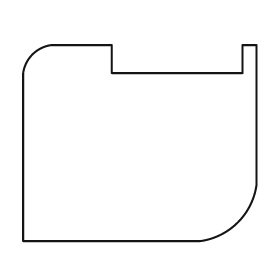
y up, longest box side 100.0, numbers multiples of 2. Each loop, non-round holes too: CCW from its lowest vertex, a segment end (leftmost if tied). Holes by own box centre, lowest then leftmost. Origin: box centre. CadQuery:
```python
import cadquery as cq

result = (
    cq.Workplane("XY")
    .moveTo(-50.0, -42.0)
    .lineTo(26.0, -42.0)
    .threePointArc((42.0, -34.0), (50.0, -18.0))
    .lineTo(50.0, 42.0)
    .lineTo(44.0, 42.0)
    .lineTo(44.0, 30.0)
    .lineTo(-12.0, 30.0)
    .lineTo(-12.0, 42.0)
    .lineTo(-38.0, 42.0)
    .threePointArc((-46.0, 38.0), (-50.0, 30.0))
    .close()
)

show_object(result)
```